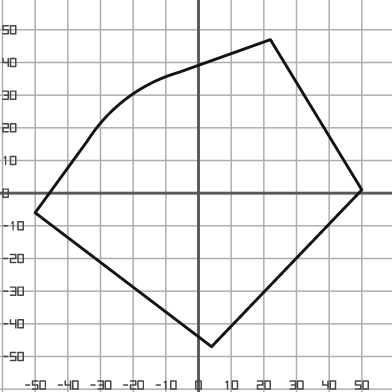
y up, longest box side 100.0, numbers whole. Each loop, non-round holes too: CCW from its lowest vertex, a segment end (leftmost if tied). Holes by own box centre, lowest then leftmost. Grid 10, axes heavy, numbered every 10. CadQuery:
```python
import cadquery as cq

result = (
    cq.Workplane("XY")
    .moveTo(4.0, -47.0)
    .lineTo(50.0, 1.0)
    .lineTo(22.0, 47.0)
    .lineTo(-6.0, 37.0)
    .threePointArc((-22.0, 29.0), (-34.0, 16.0))
    .lineTo(-50.0, -6.0)
    .close()
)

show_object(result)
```